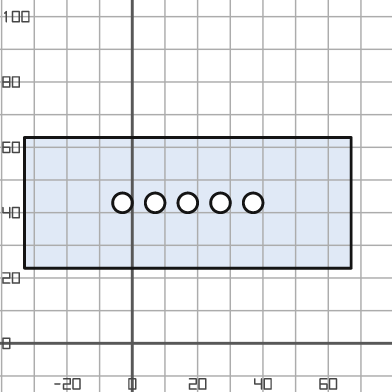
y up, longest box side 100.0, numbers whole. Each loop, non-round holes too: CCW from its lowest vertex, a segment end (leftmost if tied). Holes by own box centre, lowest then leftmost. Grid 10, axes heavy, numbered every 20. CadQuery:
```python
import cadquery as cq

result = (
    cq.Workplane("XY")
    .moveTo(-33.0, 23.0)
    .lineTo(67.0, 23.0)
    .lineTo(67.0, 63.0)
    .lineTo(-33.0, 63.0)
    .close()
    .moveTo(-3.0, 43.0)
    .circle(3.0)
    .moveTo(7.0, 43.0)
    .circle(3.0)
    .moveTo(17.0, 43.0)
    .circle(3.0)
    .moveTo(27.0, 43.0)
    .circle(3.0)
    .moveTo(37.0, 43.0)
    .circle(3.0)
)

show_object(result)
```